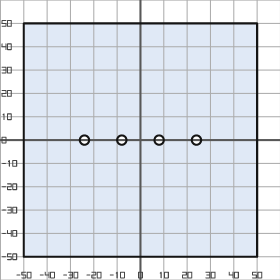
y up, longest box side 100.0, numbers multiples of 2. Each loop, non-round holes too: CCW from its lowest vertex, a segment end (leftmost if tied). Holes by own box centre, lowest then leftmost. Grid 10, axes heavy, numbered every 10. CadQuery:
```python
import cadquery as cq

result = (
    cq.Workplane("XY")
    .moveTo(-50.0, -50.0)
    .lineTo(50.0, -50.0)
    .lineTo(50.0, 50.0)
    .lineTo(-50.0, 50.0)
    .close()
    .moveTo(-24.0, 0.0)
    .circle(2.0)
    .moveTo(-8.0, 0.0)
    .circle(2.0)
    .moveTo(8.0, 0.0)
    .circle(2.0)
    .moveTo(24.0, 0.0)
    .circle(2.0)
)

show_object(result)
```